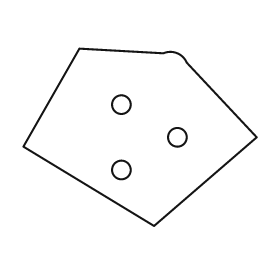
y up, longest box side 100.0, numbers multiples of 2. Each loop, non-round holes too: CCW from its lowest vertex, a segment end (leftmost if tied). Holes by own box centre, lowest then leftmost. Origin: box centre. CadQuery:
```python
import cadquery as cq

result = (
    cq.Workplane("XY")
    .moveTo(6.0, -38.0)
    .lineTo(50.0, 0.0)
    .lineTo(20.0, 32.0)
    .threePointArc((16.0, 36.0), (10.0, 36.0))
    .lineTo(-26.0, 38.0)
    .lineTo(-50.0, -4.0)
    .close()
    .moveTo(-8.0, -14.0)
    .circle(4.0)
    .moveTo(16.0, 0.0)
    .circle(4.0)
    .moveTo(-8.0, 14.0)
    .circle(4.0)
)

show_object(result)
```